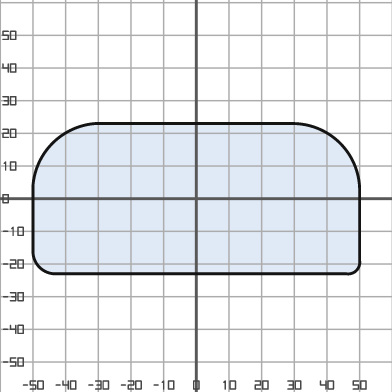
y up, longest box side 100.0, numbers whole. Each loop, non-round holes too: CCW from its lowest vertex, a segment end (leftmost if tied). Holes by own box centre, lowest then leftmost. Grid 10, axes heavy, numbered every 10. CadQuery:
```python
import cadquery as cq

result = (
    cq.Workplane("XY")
    .moveTo(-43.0, -23.0)
    .lineTo(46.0, -23.0)
    .threePointArc((49.0, -22.0), (50.0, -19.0))
    .lineTo(50.0, 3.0)
    .threePointArc((44.0, 17.0), (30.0, 23.0))
    .lineTo(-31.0, 23.0)
    .threePointArc((-44.0, 17.0), (-50.0, 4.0))
    .lineTo(-50.0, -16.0)
    .threePointArc((-48.0, -21.0), (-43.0, -23.0))
    .close()
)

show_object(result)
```